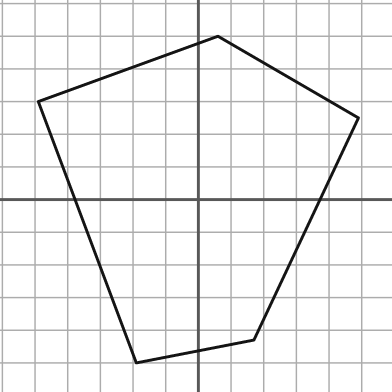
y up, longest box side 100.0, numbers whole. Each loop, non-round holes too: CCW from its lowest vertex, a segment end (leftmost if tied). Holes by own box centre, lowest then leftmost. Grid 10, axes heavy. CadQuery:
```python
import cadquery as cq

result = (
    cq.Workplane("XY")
    .moveTo(-19.0, -50.0)
    .lineTo(17.0, -43.0)
    .lineTo(49.0, 25.0)
    .lineTo(6.0, 50.0)
    .lineTo(-49.0, 30.0)
    .close()
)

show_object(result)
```